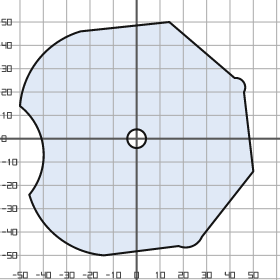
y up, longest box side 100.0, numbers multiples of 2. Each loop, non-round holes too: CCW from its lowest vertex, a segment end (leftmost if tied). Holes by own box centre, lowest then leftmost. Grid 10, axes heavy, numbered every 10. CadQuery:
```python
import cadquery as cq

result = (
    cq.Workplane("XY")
    .moveTo(-14.0, -50.0)
    .lineTo(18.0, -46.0)
    .threePointArc((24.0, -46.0), (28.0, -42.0))
    .lineTo(50.0, -14.0)
    .lineTo(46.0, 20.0)
    .threePointArc((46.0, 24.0), (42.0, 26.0))
    .lineTo(14.0, 50.0)
    .lineTo(-24.0, 46.0)
    .threePointArc((-42.0, 34.0), (-50.0, 14.0))
    .threePointArc((-40.0, -4.0), (-46.0, -24.0))
    .threePointArc((-34.0, -42.0), (-14.0, -50.0))
    .close()
    .moveTo(0.0, 0.0)
    .circle(4.0)
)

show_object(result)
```